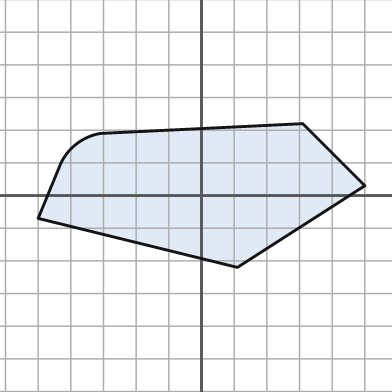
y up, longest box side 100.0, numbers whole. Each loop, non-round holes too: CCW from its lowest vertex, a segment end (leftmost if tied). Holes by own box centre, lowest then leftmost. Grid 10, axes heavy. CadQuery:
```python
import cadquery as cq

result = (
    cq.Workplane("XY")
    .moveTo(11.0, -22.0)
    .lineTo(50.0, 3.0)
    .lineTo(31.0, 22.0)
    .lineTo(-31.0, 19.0)
    .threePointArc((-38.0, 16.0), (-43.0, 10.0))
    .lineTo(-50.0, -7.0)
    .close()
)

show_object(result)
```